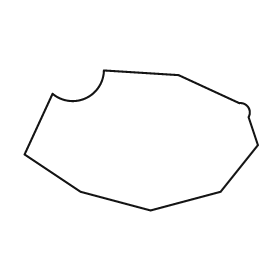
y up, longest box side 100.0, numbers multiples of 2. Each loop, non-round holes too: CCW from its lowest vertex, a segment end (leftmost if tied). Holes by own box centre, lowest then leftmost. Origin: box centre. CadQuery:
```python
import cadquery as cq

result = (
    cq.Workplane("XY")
    .moveTo(4.0, -30.0)
    .lineTo(34.0, -22.0)
    .lineTo(50.0, -2.0)
    .lineTo(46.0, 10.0)
    .threePointArc((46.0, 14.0), (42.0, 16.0))
    .lineTo(16.0, 28.0)
    .lineTo(-16.0, 30.0)
    .threePointArc((-24.0, 18.0), (-38.0, 20.0))
    .lineTo(-50.0, -6.0)
    .lineTo(-26.0, -22.0)
    .close()
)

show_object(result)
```